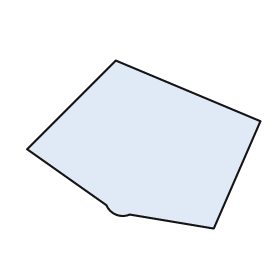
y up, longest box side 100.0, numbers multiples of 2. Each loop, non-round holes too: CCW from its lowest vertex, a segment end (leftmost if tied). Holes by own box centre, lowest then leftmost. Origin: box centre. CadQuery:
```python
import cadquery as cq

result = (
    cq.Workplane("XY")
    .moveTo(30.0, -36.0)
    .lineTo(50.0, 10.0)
    .lineTo(-12.0, 36.0)
    .lineTo(-50.0, -2.0)
    .lineTo(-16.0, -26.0)
    .threePointArc((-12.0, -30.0), (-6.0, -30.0))
    .close()
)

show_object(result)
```